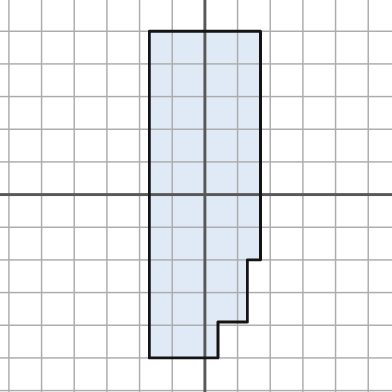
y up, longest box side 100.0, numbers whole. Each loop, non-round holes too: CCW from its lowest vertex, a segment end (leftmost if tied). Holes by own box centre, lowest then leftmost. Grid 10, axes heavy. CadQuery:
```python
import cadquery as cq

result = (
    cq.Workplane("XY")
    .moveTo(-17.0, -50.0)
    .lineTo(4.0, -50.0)
    .lineTo(4.0, -39.0)
    .lineTo(13.0, -39.0)
    .lineTo(13.0, -20.0)
    .lineTo(17.0, -20.0)
    .lineTo(17.0, 50.0)
    .lineTo(-17.0, 50.0)
    .close()
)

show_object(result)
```